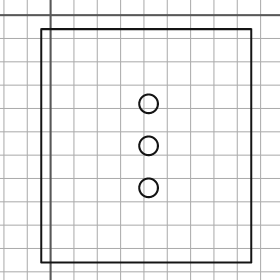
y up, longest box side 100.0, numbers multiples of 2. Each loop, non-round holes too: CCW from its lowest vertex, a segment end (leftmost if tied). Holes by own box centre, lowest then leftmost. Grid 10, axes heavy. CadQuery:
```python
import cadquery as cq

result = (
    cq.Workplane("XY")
    .moveTo(-4.0, -106.0)
    .lineTo(86.0, -106.0)
    .lineTo(86.0, -6.0)
    .lineTo(-4.0, -6.0)
    .close()
    .moveTo(42.0, -74.0)
    .circle(4.0)
    .moveTo(42.0, -56.0)
    .circle(4.0)
    .moveTo(42.0, -38.0)
    .circle(4.0)
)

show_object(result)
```